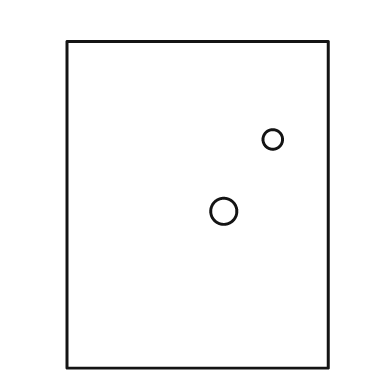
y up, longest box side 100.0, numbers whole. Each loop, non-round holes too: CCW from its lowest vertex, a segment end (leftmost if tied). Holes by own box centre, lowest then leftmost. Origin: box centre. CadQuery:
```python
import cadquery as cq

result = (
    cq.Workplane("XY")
    .moveTo(-40.0, -50.0)
    .lineTo(40.0, -50.0)
    .lineTo(40.0, 50.0)
    .lineTo(-40.0, 50.0)
    .close()
    .moveTo(8.0, -2.0)
    .circle(4.0)
    .moveTo(23.0, 20.0)
    .circle(3.0)
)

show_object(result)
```